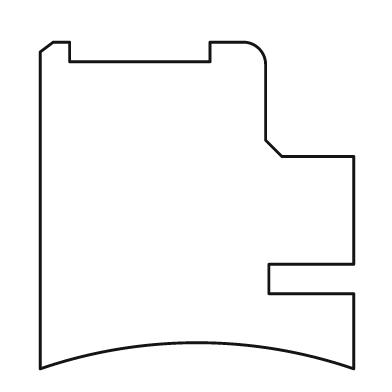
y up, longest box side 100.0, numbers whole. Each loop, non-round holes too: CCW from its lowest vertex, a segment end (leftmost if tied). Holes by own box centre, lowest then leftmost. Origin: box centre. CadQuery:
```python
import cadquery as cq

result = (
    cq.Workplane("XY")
    .moveTo(-48.0, -50.0)
    .threePointArc((0.0, -42.0), (48.0, -50.0))
    .lineTo(48.0, -27.0)
    .lineTo(22.0, -27.0)
    .lineTo(22.0, -18.0)
    .lineTo(48.0, -18.0)
    .lineTo(48.0, 15.0)
    .lineTo(26.0, 15.0)
    .lineTo(21.0, 20.0)
    .lineTo(21.0, 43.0)
    .threePointArc((19.0, 48.0), (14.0, 50.0))
    .lineTo(4.0, 50.0)
    .lineTo(4.0, 44.0)
    .lineTo(-39.0, 44.0)
    .lineTo(-39.0, 50.0)
    .lineTo(-44.0, 50.0)
    .lineTo(-48.0, 47.0)
    .close()
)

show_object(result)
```